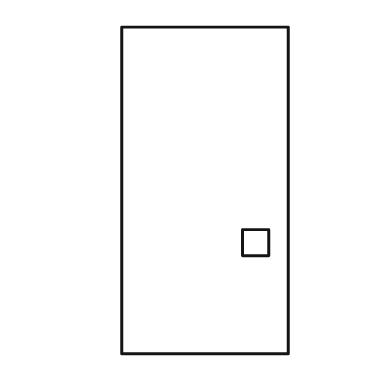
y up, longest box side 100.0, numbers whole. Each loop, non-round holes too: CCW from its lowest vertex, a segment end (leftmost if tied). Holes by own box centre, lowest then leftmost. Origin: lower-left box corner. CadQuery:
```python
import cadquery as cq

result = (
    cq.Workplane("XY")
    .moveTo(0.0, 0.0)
    .lineTo(51.0, 0.0)
    .lineTo(51.0, 100.0)
    .lineTo(0.0, 100.0)
    .close()
    .moveTo(37.0, 30.0)
    .lineTo(45.0, 30.0)
    .lineTo(45.0, 38.0)
    .lineTo(37.0, 38.0)
    .close()
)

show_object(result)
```